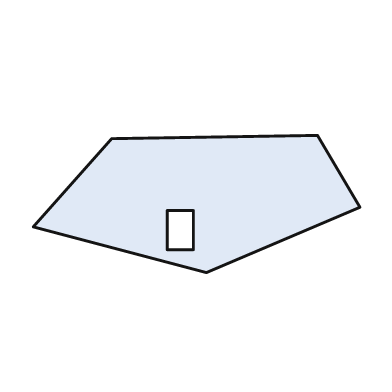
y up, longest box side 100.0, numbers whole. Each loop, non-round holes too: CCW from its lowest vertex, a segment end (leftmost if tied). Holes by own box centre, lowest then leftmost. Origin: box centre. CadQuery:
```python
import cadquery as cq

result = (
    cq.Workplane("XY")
    .moveTo(3.0, -21.0)
    .lineTo(50.0, -1.0)
    .lineTo(37.0, 21.0)
    .lineTo(-26.0, 20.0)
    .lineTo(-50.0, -7.0)
    .close()
    .moveTo(-9.0, -14.0)
    .lineTo(-1.0, -14.0)
    .lineTo(-1.0, -2.0)
    .lineTo(-9.0, -2.0)
    .close()
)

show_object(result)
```